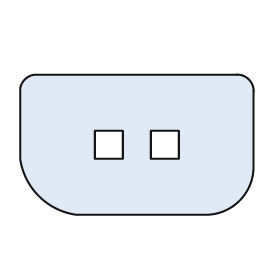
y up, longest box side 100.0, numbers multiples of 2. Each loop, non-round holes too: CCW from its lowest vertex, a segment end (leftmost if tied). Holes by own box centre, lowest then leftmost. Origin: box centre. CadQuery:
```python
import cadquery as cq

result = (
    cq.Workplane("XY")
    .moveTo(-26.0, -30.0)
    .lineTo(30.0, -30.0)
    .threePointArc((44.0, -24.0), (50.0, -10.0))
    .lineTo(50.0, 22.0)
    .threePointArc((48.0, 28.0), (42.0, 30.0))
    .lineTo(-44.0, 30.0)
    .threePointArc((-48.0, 28.0), (-50.0, 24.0))
    .lineTo(-50.0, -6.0)
    .threePointArc((-42.0, -22.0), (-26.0, -30.0))
    .close()
    .moveTo(-18.0, -6.0)
    .lineTo(-6.0, -6.0)
    .lineTo(-6.0, 6.0)
    .lineTo(-18.0, 6.0)
    .close()
    .moveTo(6.0, -6.0)
    .lineTo(18.0, -6.0)
    .lineTo(18.0, 6.0)
    .lineTo(6.0, 6.0)
    .close()
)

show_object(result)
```